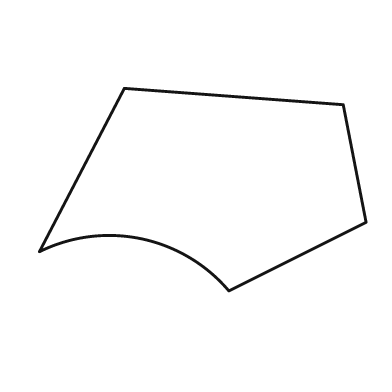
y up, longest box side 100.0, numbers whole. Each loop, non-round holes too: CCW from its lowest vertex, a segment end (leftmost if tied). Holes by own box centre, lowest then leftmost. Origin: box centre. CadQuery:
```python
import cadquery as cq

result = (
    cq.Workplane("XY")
    .moveTo(8.0, -31.0)
    .lineTo(50.0, -10.0)
    .lineTo(43.0, 26.0)
    .lineTo(-24.0, 31.0)
    .lineTo(-50.0, -19.0)
    .threePointArc((-19.0, -15.0), (8.0, -31.0))
    .close()
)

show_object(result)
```